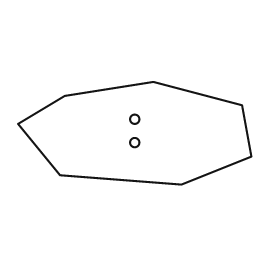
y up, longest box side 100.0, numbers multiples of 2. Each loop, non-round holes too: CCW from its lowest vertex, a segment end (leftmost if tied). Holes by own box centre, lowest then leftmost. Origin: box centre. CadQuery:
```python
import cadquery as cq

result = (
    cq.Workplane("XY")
    .moveTo(20.0, -22.0)
    .lineTo(50.0, -10.0)
    .lineTo(46.0, 12.0)
    .lineTo(8.0, 22.0)
    .lineTo(-30.0, 16.0)
    .lineTo(-50.0, 4.0)
    .lineTo(-32.0, -18.0)
    .close()
    .moveTo(0.0, -4.0)
    .circle(2.0)
    .moveTo(0.0, 6.0)
    .circle(2.0)
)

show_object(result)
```